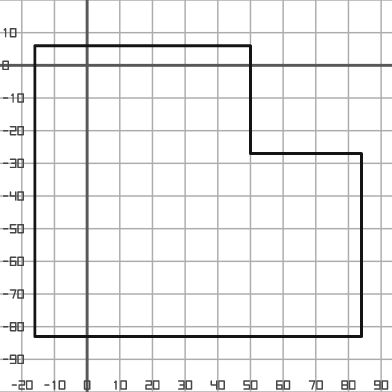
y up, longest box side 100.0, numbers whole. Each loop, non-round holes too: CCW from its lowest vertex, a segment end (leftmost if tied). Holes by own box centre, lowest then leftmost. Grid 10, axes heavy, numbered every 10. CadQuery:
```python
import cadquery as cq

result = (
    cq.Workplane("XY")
    .moveTo(-16.0, -83.0)
    .lineTo(84.0, -83.0)
    .lineTo(84.0, -27.0)
    .lineTo(50.0, -27.0)
    .lineTo(50.0, 6.0)
    .lineTo(-16.0, 6.0)
    .close()
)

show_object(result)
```